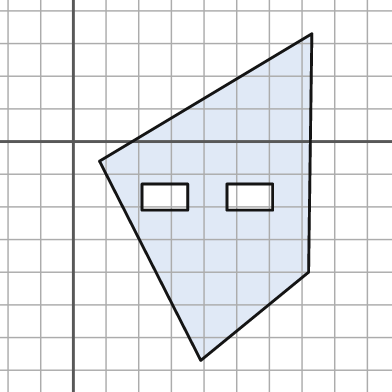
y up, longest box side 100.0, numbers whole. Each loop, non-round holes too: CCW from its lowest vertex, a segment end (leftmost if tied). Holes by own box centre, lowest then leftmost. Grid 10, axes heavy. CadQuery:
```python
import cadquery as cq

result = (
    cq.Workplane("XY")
    .moveTo(39.0, -67.0)
    .lineTo(72.0, -40.0)
    .lineTo(73.0, 33.0)
    .lineTo(8.0, -6.0)
    .close()
    .moveTo(21.0, -21.0)
    .lineTo(35.0, -21.0)
    .lineTo(35.0, -13.0)
    .lineTo(21.0, -13.0)
    .close()
    .moveTo(47.0, -21.0)
    .lineTo(61.0, -21.0)
    .lineTo(61.0, -13.0)
    .lineTo(47.0, -13.0)
    .close()
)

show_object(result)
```